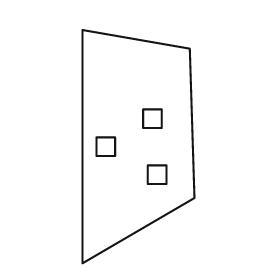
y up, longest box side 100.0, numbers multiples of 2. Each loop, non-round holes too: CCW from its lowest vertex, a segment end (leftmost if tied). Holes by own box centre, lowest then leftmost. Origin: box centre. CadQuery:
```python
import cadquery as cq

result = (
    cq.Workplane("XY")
    .moveTo(-24.0, -50.0)
    .lineTo(24.0, -22.0)
    .lineTo(22.0, 42.0)
    .lineTo(-24.0, 50.0)
    .close()
    .moveTo(4.0, -16.0)
    .lineTo(12.0, -16.0)
    .lineTo(12.0, -8.0)
    .lineTo(4.0, -8.0)
    .close()
    .moveTo(-18.0, -4.0)
    .lineTo(-10.0, -4.0)
    .lineTo(-10.0, 4.0)
    .lineTo(-18.0, 4.0)
    .close()
    .moveTo(2.0, 8.0)
    .lineTo(10.0, 8.0)
    .lineTo(10.0, 16.0)
    .lineTo(2.0, 16.0)
    .close()
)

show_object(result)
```